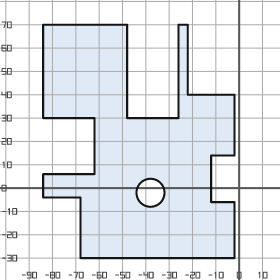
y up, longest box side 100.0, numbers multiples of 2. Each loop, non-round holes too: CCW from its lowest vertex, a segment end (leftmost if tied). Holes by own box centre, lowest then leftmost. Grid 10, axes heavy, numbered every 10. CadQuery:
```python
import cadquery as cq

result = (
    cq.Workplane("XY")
    .moveTo(-68.0, -30.0)
    .lineTo(-2.0, -30.0)
    .lineTo(-2.0, -6.0)
    .lineTo(-12.0, -6.0)
    .lineTo(-12.0, 14.0)
    .lineTo(-2.0, 14.0)
    .lineTo(-2.0, 40.0)
    .lineTo(-22.0, 40.0)
    .lineTo(-22.0, 70.0)
    .lineTo(-26.0, 70.0)
    .lineTo(-26.0, 30.0)
    .lineTo(-48.0, 30.0)
    .lineTo(-48.0, 70.0)
    .lineTo(-84.0, 70.0)
    .lineTo(-84.0, 30.0)
    .lineTo(-62.0, 30.0)
    .lineTo(-62.0, 6.0)
    .lineTo(-84.0, 6.0)
    .lineTo(-84.0, -4.0)
    .lineTo(-68.0, -4.0)
    .close()
    .moveTo(-38.0, -2.0)
    .circle(6.0)
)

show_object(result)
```